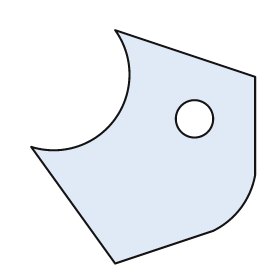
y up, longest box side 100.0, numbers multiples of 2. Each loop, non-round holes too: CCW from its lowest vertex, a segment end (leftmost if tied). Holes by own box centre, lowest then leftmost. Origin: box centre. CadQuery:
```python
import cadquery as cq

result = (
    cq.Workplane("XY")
    .moveTo(-12.0, -50.0)
    .lineTo(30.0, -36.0)
    .threePointArc((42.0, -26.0), (48.0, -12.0))
    .lineTo(48.0, 30.0)
    .lineTo(-12.0, 50.0)
    .threePointArc((-12.0, 12.0), (-48.0, 0.0))
    .close()
    .moveTo(22.0, 12.0)
    .circle(8.0)
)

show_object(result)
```